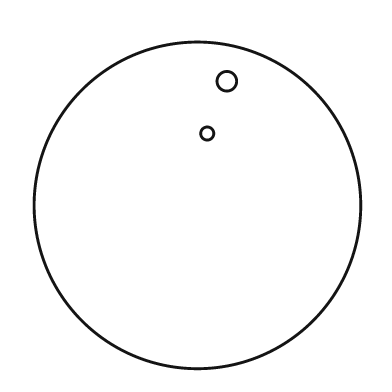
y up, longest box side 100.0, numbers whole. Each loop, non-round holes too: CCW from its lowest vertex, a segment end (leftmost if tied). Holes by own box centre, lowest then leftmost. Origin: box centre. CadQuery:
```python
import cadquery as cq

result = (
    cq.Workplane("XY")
    .moveTo(0.0, 0.0)
    .circle(50.0)
    .moveTo(3.0, 22.0)
    .circle(2.0)
    .moveTo(9.0, 38.0)
    .circle(3.0)
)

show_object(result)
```